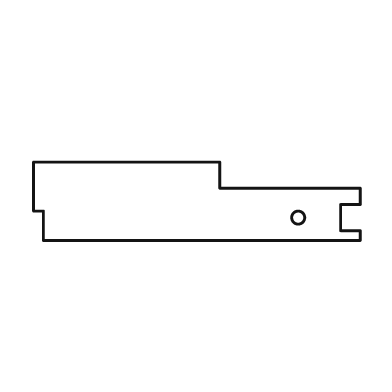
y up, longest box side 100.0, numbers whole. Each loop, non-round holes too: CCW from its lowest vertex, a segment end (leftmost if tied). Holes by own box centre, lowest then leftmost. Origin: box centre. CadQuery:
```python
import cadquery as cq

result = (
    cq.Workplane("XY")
    .moveTo(-47.0, -12.0)
    .lineTo(50.0, -12.0)
    .lineTo(50.0, -9.0)
    .lineTo(44.0, -9.0)
    .lineTo(44.0, -1.0)
    .lineTo(50.0, -1.0)
    .lineTo(50.0, 4.0)
    .lineTo(7.0, 4.0)
    .lineTo(7.0, 12.0)
    .lineTo(-50.0, 12.0)
    .lineTo(-50.0, -3.0)
    .lineTo(-47.0, -3.0)
    .close()
    .moveTo(31.0, -5.0)
    .circle(2.0)
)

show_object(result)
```